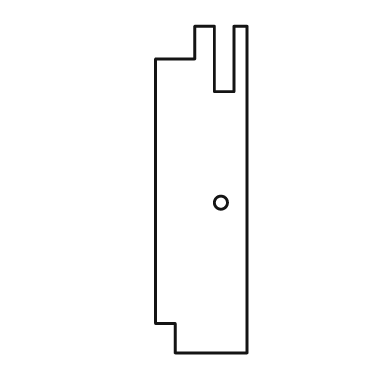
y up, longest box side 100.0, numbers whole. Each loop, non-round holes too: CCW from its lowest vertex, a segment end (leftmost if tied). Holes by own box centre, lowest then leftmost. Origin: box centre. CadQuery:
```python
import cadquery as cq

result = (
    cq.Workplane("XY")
    .moveTo(-8.0, -50.0)
    .lineTo(14.0, -50.0)
    .lineTo(14.0, 50.0)
    .lineTo(10.0, 50.0)
    .lineTo(10.0, 30.0)
    .lineTo(4.0, 30.0)
    .lineTo(4.0, 50.0)
    .lineTo(-2.0, 50.0)
    .lineTo(-2.0, 40.0)
    .lineTo(-14.0, 40.0)
    .lineTo(-14.0, -41.0)
    .lineTo(-8.0, -41.0)
    .close()
    .moveTo(6.0, -4.0)
    .circle(2.0)
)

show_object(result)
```